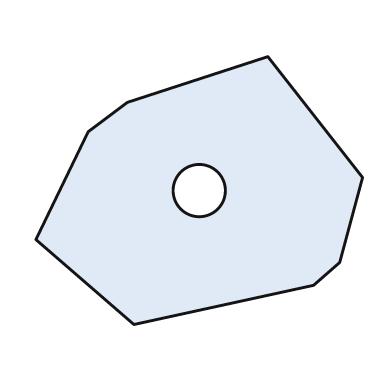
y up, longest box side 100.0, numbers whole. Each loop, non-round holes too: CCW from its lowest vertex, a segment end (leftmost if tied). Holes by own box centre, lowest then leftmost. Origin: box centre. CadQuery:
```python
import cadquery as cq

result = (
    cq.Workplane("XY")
    .moveTo(-20.0, -41.0)
    .lineTo(35.0, -29.0)
    .lineTo(43.0, -22.0)
    .lineTo(50.0, 4.0)
    .lineTo(21.0, 41.0)
    .lineTo(-22.0, 27.0)
    .lineTo(-34.0, 18.0)
    .lineTo(-50.0, -15.0)
    .close()
    .moveTo(0.0, 0.0)
    .circle(8.0)
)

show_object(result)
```